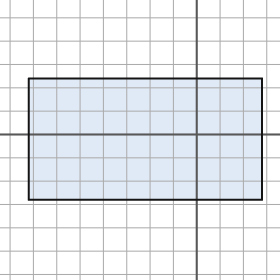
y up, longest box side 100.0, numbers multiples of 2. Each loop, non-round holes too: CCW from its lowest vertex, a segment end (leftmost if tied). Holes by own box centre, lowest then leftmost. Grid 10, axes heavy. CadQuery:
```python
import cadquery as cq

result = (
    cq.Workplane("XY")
    .moveTo(-72.0, -28.0)
    .lineTo(28.0, -28.0)
    .lineTo(28.0, 24.0)
    .lineTo(-72.0, 24.0)
    .close()
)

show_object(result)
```